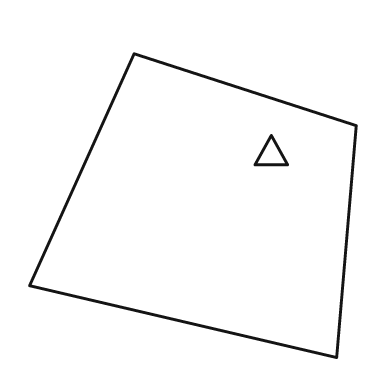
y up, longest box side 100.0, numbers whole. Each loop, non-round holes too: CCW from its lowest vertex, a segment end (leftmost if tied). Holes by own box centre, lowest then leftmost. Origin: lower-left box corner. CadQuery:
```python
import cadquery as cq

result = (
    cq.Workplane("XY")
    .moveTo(94.0, 0.0)
    .lineTo(100.0, 71.0)
    .lineTo(32.0, 93.0)
    .lineTo(0.0, 22.0)
    .close()
    .moveTo(69.0, 59.0)
    .lineTo(79.0, 59.0)
    .lineTo(74.0, 68.0)
    .close()
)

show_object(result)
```